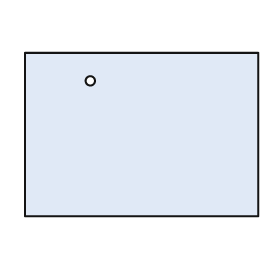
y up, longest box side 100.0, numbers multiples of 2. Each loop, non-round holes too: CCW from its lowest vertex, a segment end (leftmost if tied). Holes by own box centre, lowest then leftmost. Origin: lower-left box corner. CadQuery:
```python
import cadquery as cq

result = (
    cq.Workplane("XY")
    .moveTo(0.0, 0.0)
    .lineTo(100.0, 0.0)
    .lineTo(100.0, 70.0)
    .lineTo(0.0, 70.0)
    .close()
    .moveTo(28.0, 58.0)
    .circle(2.0)
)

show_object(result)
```